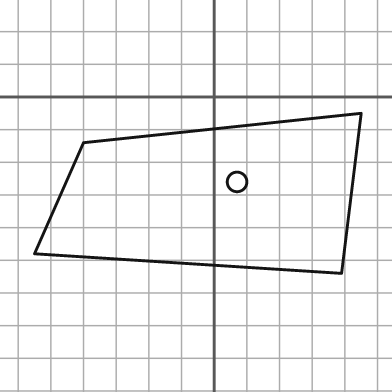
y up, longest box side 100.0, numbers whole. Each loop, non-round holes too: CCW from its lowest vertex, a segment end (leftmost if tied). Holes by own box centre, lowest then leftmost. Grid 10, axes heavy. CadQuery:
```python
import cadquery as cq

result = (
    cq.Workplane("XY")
    .moveTo(39.0, -54.0)
    .lineTo(45.0, -5.0)
    .lineTo(-40.0, -14.0)
    .lineTo(-55.0, -48.0)
    .close()
    .moveTo(7.0, -26.0)
    .circle(3.0)
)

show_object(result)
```